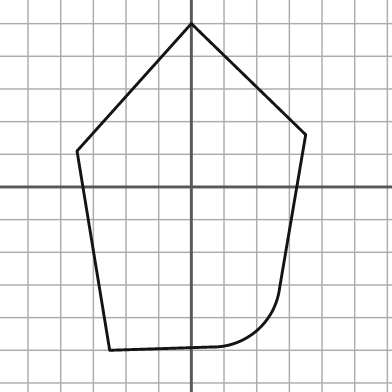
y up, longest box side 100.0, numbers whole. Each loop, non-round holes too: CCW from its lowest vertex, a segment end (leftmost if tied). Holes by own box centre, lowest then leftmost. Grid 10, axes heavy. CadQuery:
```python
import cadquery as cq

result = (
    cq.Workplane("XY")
    .moveTo(-25.0, -50.0)
    .lineTo(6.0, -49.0)
    .threePointArc((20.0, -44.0), (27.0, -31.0))
    .lineTo(35.0, 16.0)
    .lineTo(0.0, 50.0)
    .lineTo(-35.0, 11.0)
    .close()
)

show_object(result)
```